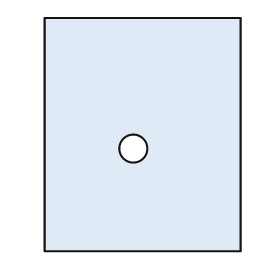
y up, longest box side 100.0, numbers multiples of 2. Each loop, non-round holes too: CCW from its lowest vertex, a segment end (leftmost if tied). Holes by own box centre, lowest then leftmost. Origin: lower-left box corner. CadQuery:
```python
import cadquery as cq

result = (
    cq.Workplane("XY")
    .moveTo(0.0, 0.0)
    .lineTo(84.0, 0.0)
    .lineTo(84.0, 100.0)
    .lineTo(0.0, 100.0)
    .close()
    .moveTo(38.0, 44.0)
    .circle(6.0)
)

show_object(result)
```